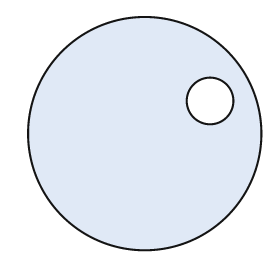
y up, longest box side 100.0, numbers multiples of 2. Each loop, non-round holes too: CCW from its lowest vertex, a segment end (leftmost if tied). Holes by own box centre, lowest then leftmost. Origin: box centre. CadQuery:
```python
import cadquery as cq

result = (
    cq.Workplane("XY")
    .moveTo(0.0, 0.0)
    .circle(50.0)
    .moveTo(28.0, 14.0)
    .circle(10.0)
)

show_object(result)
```